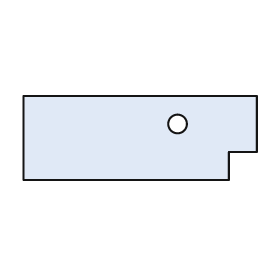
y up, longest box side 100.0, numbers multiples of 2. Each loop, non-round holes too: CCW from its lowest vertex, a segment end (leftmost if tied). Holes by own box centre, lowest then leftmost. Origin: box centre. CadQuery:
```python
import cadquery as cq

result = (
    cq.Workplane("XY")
    .moveTo(-50.0, -18.0)
    .lineTo(38.0, -18.0)
    .lineTo(38.0, -6.0)
    .lineTo(50.0, -6.0)
    .lineTo(50.0, 18.0)
    .lineTo(-50.0, 18.0)
    .close()
    .moveTo(16.0, 6.0)
    .circle(4.0)
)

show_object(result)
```